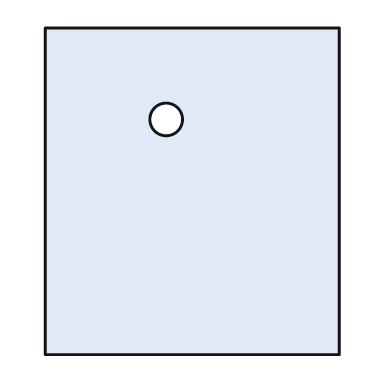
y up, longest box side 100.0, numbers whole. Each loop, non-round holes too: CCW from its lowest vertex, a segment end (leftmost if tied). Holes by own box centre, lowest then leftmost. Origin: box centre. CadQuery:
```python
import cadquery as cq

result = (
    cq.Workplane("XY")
    .moveTo(-45.0, -50.0)
    .lineTo(45.0, -50.0)
    .lineTo(45.0, 50.0)
    .lineTo(-45.0, 50.0)
    .close()
    .moveTo(-8.0, 22.0)
    .circle(5.0)
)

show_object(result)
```